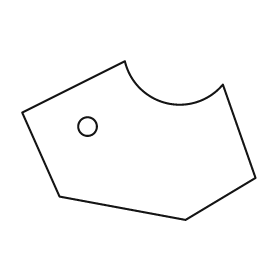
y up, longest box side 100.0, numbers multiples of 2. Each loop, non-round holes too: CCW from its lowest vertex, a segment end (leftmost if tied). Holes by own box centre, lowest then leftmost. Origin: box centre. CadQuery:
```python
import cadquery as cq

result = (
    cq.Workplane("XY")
    .moveTo(20.0, -34.0)
    .lineTo(50.0, -16.0)
    .lineTo(36.0, 24.0)
    .threePointArc((12.0, 16.0), (-6.0, 34.0))
    .lineTo(-50.0, 12.0)
    .lineTo(-34.0, -24.0)
    .close()
    .moveTo(-22.0, 6.0)
    .circle(4.0)
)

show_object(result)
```